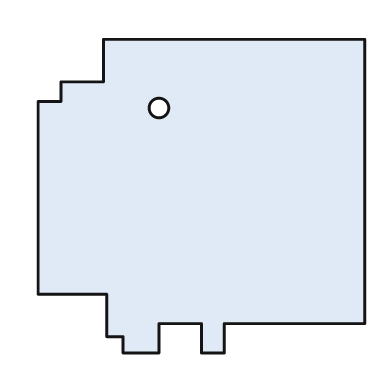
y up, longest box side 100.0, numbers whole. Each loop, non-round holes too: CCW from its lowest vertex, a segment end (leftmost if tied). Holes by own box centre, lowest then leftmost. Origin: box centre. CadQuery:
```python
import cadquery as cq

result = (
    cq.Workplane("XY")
    .moveTo(-24.0, -48.0)
    .lineTo(-13.0, -48.0)
    .lineTo(-13.0, -39.0)
    .lineTo(0.0, -39.0)
    .lineTo(0.0, -48.0)
    .lineTo(7.0, -48.0)
    .lineTo(7.0, -39.0)
    .lineTo(50.0, -39.0)
    .lineTo(50.0, 48.0)
    .lineTo(-30.0, 48.0)
    .lineTo(-30.0, 35.0)
    .lineTo(-43.0, 35.0)
    .lineTo(-43.0, 29.0)
    .lineTo(-50.0, 29.0)
    .lineTo(-50.0, -30.0)
    .lineTo(-29.0, -30.0)
    .lineTo(-29.0, -43.0)
    .lineTo(-24.0, -43.0)
    .close()
    .moveTo(-13.0, 27.0)
    .circle(3.0)
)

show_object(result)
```